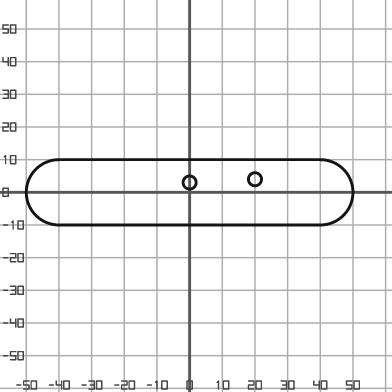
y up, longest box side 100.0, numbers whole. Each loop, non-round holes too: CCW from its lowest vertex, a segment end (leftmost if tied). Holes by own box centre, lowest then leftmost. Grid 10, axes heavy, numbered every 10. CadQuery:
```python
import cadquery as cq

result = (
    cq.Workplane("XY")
    .moveTo(-40.0, -10.0)
    .lineTo(40.0, -10.0)
    .threePointArc((50.0, 0.0), (40.0, 10.0))
    .lineTo(-40.0, 10.0)
    .threePointArc((-50.0, 0.0), (-40.0, -10.0))
    .close()
    .moveTo(0.0, 3.0)
    .circle(2.0)
    .moveTo(20.0, 4.0)
    .circle(2.0)
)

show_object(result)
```